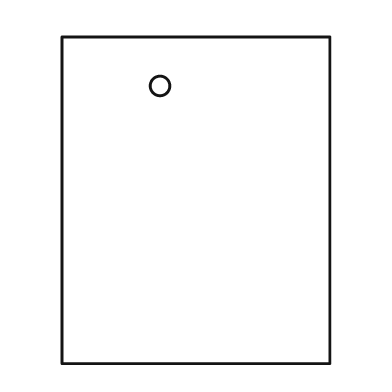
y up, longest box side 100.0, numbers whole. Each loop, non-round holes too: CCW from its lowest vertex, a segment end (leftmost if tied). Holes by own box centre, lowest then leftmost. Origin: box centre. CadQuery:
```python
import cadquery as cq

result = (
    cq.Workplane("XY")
    .moveTo(-41.0, -50.0)
    .lineTo(41.0, -50.0)
    .lineTo(41.0, 50.0)
    .lineTo(-41.0, 50.0)
    .close()
    .moveTo(-11.0, 35.0)
    .circle(3.0)
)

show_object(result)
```